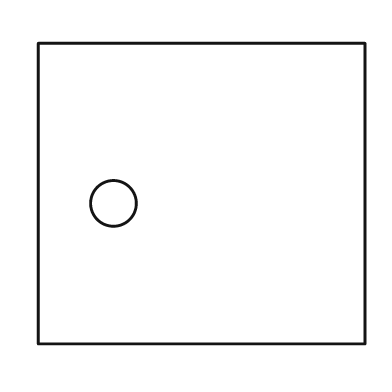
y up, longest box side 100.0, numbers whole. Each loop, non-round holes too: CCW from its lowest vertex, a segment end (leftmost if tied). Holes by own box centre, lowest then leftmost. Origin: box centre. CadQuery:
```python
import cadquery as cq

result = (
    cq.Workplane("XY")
    .moveTo(-50.0, -46.0)
    .lineTo(50.0, -46.0)
    .lineTo(50.0, 46.0)
    .lineTo(-50.0, 46.0)
    .close()
    .moveTo(-27.0, -3.0)
    .circle(7.0)
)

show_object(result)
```